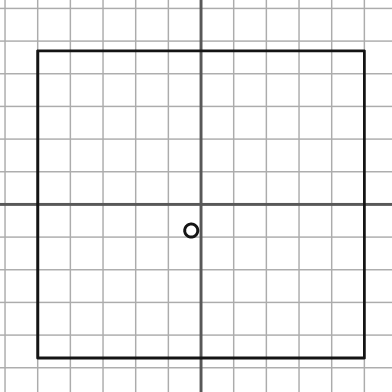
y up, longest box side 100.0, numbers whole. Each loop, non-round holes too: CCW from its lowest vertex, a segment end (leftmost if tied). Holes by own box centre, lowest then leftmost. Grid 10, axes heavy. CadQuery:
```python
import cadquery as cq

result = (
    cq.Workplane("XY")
    .moveTo(-50.0, -47.0)
    .lineTo(50.0, -47.0)
    .lineTo(50.0, 47.0)
    .lineTo(-50.0, 47.0)
    .close()
    .moveTo(-3.0, -8.0)
    .circle(2.0)
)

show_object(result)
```